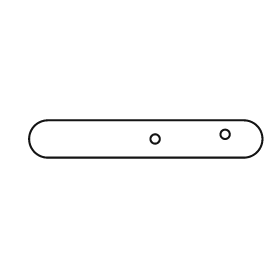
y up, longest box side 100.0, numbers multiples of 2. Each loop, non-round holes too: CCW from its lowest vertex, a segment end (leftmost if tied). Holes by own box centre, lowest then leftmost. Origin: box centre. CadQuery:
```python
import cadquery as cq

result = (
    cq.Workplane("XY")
    .moveTo(-42.0, -8.0)
    .lineTo(42.0, -8.0)
    .threePointArc((50.0, 0.0), (42.0, 8.0))
    .lineTo(-42.0, 8.0)
    .threePointArc((-50.0, 0.0), (-42.0, -8.0))
    .close()
    .moveTo(4.0, 0.0)
    .circle(2.0)
    .moveTo(34.0, 2.0)
    .circle(2.0)
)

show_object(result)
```